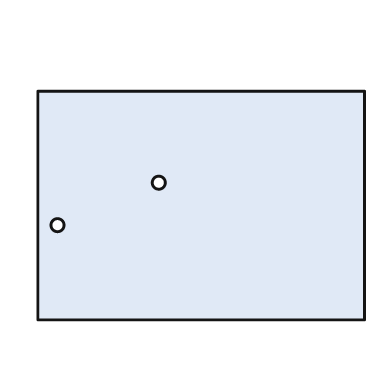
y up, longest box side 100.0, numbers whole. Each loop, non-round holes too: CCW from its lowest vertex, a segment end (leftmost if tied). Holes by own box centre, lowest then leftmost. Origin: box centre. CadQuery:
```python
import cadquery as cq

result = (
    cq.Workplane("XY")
    .moveTo(-50.0, -35.0)
    .lineTo(50.0, -35.0)
    .lineTo(50.0, 35.0)
    .lineTo(-50.0, 35.0)
    .close()
    .moveTo(-44.0, -6.0)
    .circle(2.0)
    .moveTo(-13.0, 7.0)
    .circle(2.0)
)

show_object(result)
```